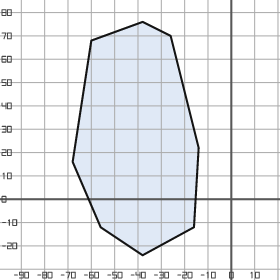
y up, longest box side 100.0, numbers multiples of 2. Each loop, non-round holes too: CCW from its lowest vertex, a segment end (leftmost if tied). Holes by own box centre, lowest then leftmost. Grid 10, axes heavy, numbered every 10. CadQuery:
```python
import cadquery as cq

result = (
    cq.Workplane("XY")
    .moveTo(-38.0, -24.0)
    .lineTo(-16.0, -12.0)
    .lineTo(-14.0, 22.0)
    .lineTo(-26.0, 70.0)
    .lineTo(-38.0, 76.0)
    .lineTo(-60.0, 68.0)
    .lineTo(-68.0, 16.0)
    .lineTo(-56.0, -12.0)
    .close()
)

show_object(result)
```